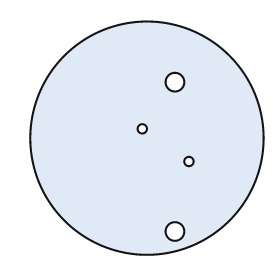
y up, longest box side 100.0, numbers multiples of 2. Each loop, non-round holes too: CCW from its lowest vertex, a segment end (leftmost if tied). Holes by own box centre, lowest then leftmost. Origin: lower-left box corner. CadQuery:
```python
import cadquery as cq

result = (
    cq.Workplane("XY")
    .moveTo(50.0, 50.0)
    .circle(50.0)
    .moveTo(62.0, 10.0)
    .circle(4.0)
    .moveTo(68.0, 40.0)
    .circle(2.0)
    .moveTo(48.0, 54.0)
    .circle(2.0)
    .moveTo(62.0, 74.0)
    .circle(4.0)
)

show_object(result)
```